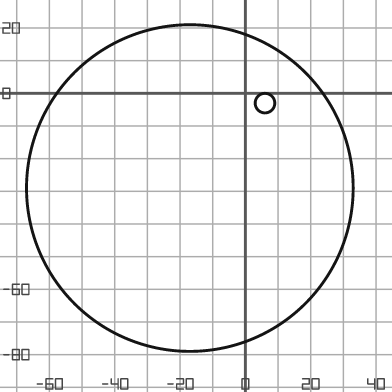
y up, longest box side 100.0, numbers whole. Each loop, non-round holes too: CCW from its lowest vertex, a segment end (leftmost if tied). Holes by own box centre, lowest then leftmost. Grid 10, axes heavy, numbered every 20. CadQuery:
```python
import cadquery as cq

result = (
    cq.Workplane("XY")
    .moveTo(-17.0, -29.0)
    .circle(50.0)
    .moveTo(6.0, -3.0)
    .circle(3.0)
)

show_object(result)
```